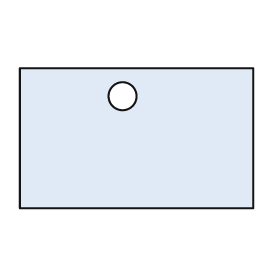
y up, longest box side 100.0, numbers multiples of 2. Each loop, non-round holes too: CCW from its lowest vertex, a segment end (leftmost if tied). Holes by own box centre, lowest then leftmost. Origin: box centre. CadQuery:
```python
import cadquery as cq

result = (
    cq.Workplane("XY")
    .moveTo(-50.0, -30.0)
    .lineTo(50.0, -30.0)
    .lineTo(50.0, 30.0)
    .lineTo(-50.0, 30.0)
    .close()
    .moveTo(-6.0, 18.0)
    .circle(6.0)
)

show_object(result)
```